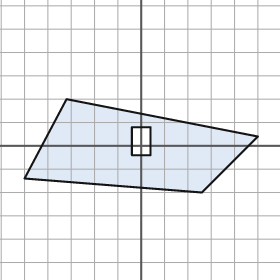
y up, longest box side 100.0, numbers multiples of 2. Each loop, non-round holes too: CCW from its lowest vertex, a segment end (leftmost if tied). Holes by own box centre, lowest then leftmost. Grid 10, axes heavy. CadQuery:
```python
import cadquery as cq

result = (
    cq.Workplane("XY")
    .moveTo(26.0, -20.0)
    .lineTo(50.0, 4.0)
    .lineTo(-32.0, 20.0)
    .lineTo(-50.0, -14.0)
    .close()
    .moveTo(-4.0, -4.0)
    .lineTo(4.0, -4.0)
    .lineTo(4.0, 8.0)
    .lineTo(-4.0, 8.0)
    .close()
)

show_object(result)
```